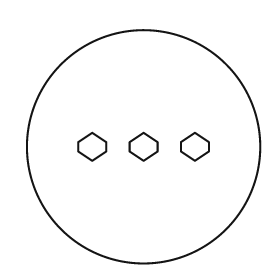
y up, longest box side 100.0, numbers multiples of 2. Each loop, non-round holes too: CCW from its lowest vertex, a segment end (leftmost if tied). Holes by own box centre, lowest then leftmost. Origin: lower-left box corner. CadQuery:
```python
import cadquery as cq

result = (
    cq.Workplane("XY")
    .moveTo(50.0, 50.0)
    .circle(50.0)
    .moveTo(28.0, 44.0)
    .lineTo(34.0, 48.0)
    .lineTo(34.0, 52.0)
    .lineTo(28.0, 56.0)
    .lineTo(22.0, 52.0)
    .lineTo(22.0, 48.0)
    .close()
    .moveTo(50.0, 44.0)
    .lineTo(56.0, 48.0)
    .lineTo(56.0, 52.0)
    .lineTo(50.0, 56.0)
    .lineTo(44.0, 52.0)
    .lineTo(44.0, 48.0)
    .close()
    .moveTo(72.0, 44.0)
    .lineTo(78.0, 48.0)
    .lineTo(78.0, 52.0)
    .lineTo(72.0, 56.0)
    .lineTo(66.0, 52.0)
    .lineTo(66.0, 48.0)
    .close()
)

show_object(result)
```